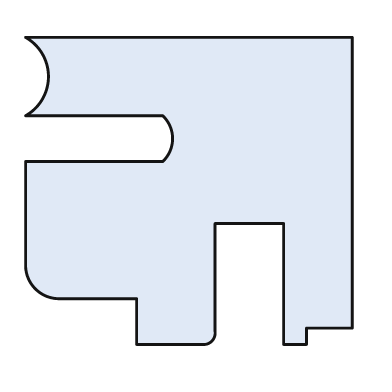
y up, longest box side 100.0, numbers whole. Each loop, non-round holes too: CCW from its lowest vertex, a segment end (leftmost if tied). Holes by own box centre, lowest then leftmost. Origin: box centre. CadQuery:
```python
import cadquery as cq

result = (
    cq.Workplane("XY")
    .moveTo(-16.0, -47.0)
    .lineTo(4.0, -47.0)
    .threePointArc((7.0, -46.0), (8.0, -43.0))
    .lineTo(8.0, -10.0)
    .lineTo(29.0, -10.0)
    .lineTo(29.0, -47.0)
    .lineTo(36.0, -47.0)
    .lineTo(36.0, -42.0)
    .lineTo(50.0, -42.0)
    .lineTo(50.0, 47.0)
    .lineTo(-50.0, 47.0)
    .threePointArc((-43.0, 35.0), (-50.0, 23.0))
    .lineTo(-8.0, 23.0)
    .threePointArc((-5.0, 16.0), (-8.0, 9.0))
    .lineTo(-50.0, 9.0)
    .lineTo(-50.0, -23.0)
    .threePointArc((-47.0, -30.0), (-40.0, -33.0))
    .lineTo(-16.0, -33.0)
    .close()
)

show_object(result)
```